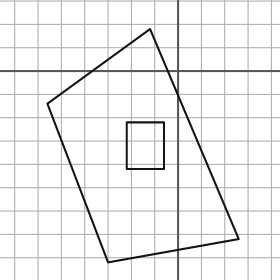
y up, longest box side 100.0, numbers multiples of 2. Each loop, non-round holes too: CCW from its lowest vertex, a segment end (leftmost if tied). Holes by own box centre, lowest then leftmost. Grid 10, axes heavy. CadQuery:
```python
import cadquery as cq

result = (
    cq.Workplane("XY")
    .moveTo(-30.0, -82.0)
    .lineTo(26.0, -72.0)
    .lineTo(-12.0, 18.0)
    .lineTo(-56.0, -14.0)
    .close()
    .moveTo(-22.0, -42.0)
    .lineTo(-6.0, -42.0)
    .lineTo(-6.0, -22.0)
    .lineTo(-22.0, -22.0)
    .close()
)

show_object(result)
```